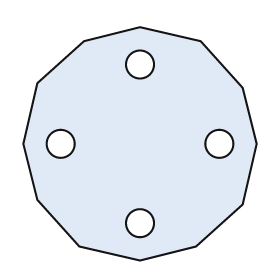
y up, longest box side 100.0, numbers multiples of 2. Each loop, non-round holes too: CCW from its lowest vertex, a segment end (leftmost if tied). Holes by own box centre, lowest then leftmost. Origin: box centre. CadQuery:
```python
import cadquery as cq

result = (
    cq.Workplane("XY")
    .moveTo(0.0, -50.0)
    .lineTo(24.0, -44.0)
    .lineTo(44.0, -26.0)
    .lineTo(50.0, 0.0)
    .lineTo(44.0, 24.0)
    .lineTo(26.0, 44.0)
    .lineTo(0.0, 50.0)
    .lineTo(-24.0, 44.0)
    .lineTo(-44.0, 26.0)
    .lineTo(-50.0, 0.0)
    .lineTo(-44.0, -24.0)
    .lineTo(-26.0, -44.0)
    .close()
    .moveTo(0.0, -34.0)
    .circle(6.0)
    .moveTo(-34.0, 0.0)
    .circle(6.0)
    .moveTo(34.0, 0.0)
    .circle(6.0)
    .moveTo(0.0, 34.0)
    .circle(6.0)
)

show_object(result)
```